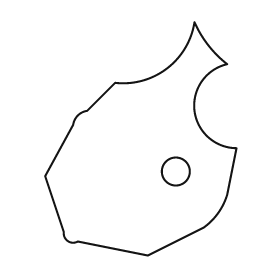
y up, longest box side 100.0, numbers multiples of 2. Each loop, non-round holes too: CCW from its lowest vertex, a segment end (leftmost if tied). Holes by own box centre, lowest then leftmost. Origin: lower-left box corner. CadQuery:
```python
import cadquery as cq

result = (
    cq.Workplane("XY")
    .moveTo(44.0, 0.0)
    .lineTo(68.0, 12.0)
    .threePointArc((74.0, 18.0), (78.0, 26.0))
    .lineTo(82.0, 46.0)
    .threePointArc((64.0, 62.0), (78.0, 82.0))
    .threePointArc((70.0, 90.0), (64.0, 100.0))
    .threePointArc((52.0, 80.0), (30.0, 74.0))
    .lineTo(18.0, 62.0)
    .threePointArc((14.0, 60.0), (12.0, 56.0))
    .lineTo(0.0, 34.0)
    .lineTo(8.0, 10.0)
    .threePointArc((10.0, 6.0), (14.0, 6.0))
    .close()
    .moveTo(56.0, 36.0)
    .circle(6.0)
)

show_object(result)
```